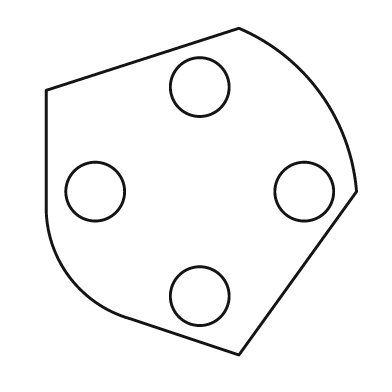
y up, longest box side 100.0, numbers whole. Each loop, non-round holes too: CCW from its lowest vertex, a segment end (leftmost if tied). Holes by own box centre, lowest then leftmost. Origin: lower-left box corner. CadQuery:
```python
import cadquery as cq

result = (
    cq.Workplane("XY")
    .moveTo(59.0, 0.0)
    .lineTo(95.0, 50.0)
    .threePointArc((84.0, 80.0), (59.0, 100.0))
    .lineTo(0.0, 81.0)
    .lineTo(0.0, 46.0)
    .threePointArc((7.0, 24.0), (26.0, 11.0))
    .close()
    .moveTo(47.0, 18.0)
    .circle(9.0)
    .moveTo(15.0, 50.0)
    .circle(9.0)
    .moveTo(79.0, 50.0)
    .circle(9.0)
    .moveTo(47.0, 82.0)
    .circle(9.0)
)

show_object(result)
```